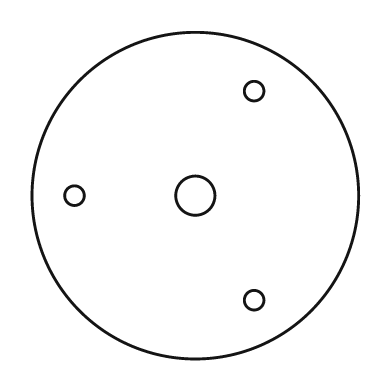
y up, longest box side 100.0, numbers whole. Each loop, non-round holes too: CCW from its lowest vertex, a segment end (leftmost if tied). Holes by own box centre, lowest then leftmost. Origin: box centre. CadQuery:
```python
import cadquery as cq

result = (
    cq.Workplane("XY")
    .moveTo(0.0, 0.0)
    .circle(50.0)
    .moveTo(18.0, -32.0)
    .circle(3.0)
    .moveTo(-37.0, 0.0)
    .circle(3.0)
    .moveTo(0.0, 0.0)
    .circle(6.0)
    .moveTo(18.0, 32.0)
    .circle(3.0)
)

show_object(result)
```